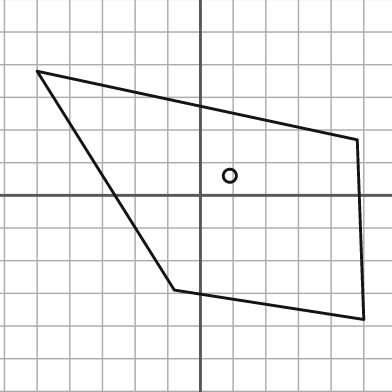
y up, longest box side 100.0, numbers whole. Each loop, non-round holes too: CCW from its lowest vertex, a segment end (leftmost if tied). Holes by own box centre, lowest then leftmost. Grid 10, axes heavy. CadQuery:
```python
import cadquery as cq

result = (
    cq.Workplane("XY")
    .moveTo(50.0, -38.0)
    .lineTo(48.0, 17.0)
    .lineTo(-50.0, 38.0)
    .lineTo(-8.0, -29.0)
    .close()
    .moveTo(9.0, 6.0)
    .circle(2.0)
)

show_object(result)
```